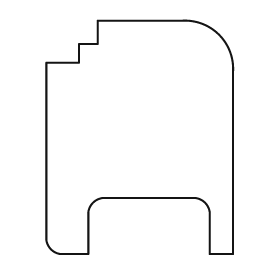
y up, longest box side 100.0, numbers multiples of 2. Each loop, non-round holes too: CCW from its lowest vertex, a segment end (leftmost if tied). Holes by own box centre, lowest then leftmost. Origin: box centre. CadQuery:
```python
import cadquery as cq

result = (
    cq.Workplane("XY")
    .moveTo(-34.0, -50.0)
    .lineTo(-22.0, -50.0)
    .lineTo(-22.0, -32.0)
    .threePointArc((-20.0, -28.0), (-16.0, -26.0))
    .lineTo(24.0, -26.0)
    .threePointArc((28.0, -28.0), (30.0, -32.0))
    .lineTo(30.0, -50.0)
    .lineTo(40.0, -50.0)
    .lineTo(40.0, 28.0)
    .threePointArc((34.0, 44.0), (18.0, 50.0))
    .lineTo(-18.0, 50.0)
    .lineTo(-18.0, 40.0)
    .lineTo(-26.0, 40.0)
    .lineTo(-26.0, 32.0)
    .lineTo(-40.0, 32.0)
    .lineTo(-40.0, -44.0)
    .threePointArc((-38.0, -48.0), (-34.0, -50.0))
    .close()
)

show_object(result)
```